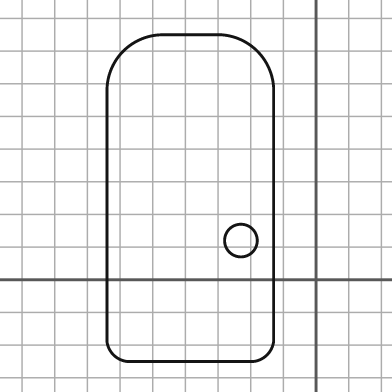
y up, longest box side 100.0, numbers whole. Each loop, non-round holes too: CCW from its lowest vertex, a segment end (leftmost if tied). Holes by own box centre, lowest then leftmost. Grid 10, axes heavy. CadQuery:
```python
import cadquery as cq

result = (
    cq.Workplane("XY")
    .moveTo(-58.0, -25.0)
    .lineTo(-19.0, -25.0)
    .threePointArc((-15.0, -23.0), (-13.0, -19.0))
    .lineTo(-13.0, 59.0)
    .threePointArc((-18.0, 70.0), (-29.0, 75.0))
    .lineTo(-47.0, 75.0)
    .threePointArc((-59.0, 70.0), (-64.0, 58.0))
    .lineTo(-64.0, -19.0)
    .threePointArc((-62.0, -23.0), (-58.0, -25.0))
    .close()
    .moveTo(-23.0, 12.0)
    .circle(5.0)
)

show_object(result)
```